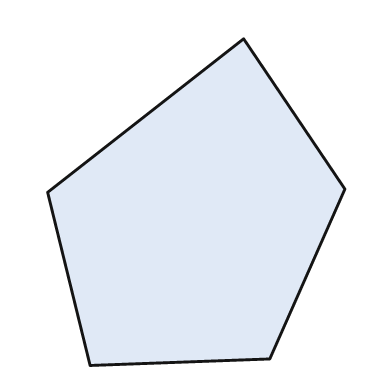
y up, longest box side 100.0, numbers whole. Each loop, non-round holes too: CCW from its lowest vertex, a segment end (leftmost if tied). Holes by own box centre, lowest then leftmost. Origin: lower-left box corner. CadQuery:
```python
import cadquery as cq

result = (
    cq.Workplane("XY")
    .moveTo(13.0, 0.0)
    .lineTo(68.0, 2.0)
    .lineTo(91.0, 54.0)
    .lineTo(60.0, 100.0)
    .lineTo(0.0, 53.0)
    .close()
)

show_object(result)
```